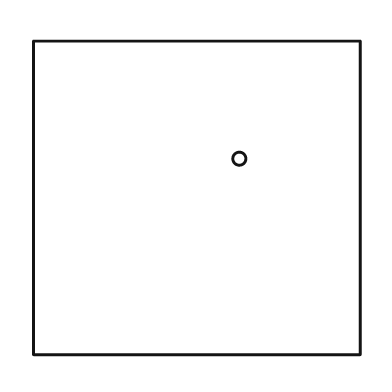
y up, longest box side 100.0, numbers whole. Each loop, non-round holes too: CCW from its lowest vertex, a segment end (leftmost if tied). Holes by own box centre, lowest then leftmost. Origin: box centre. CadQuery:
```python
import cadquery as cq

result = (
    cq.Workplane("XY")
    .moveTo(-50.0, -48.0)
    .lineTo(50.0, -48.0)
    .lineTo(50.0, 48.0)
    .lineTo(-50.0, 48.0)
    .close()
    .moveTo(13.0, 12.0)
    .circle(2.0)
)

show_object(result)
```